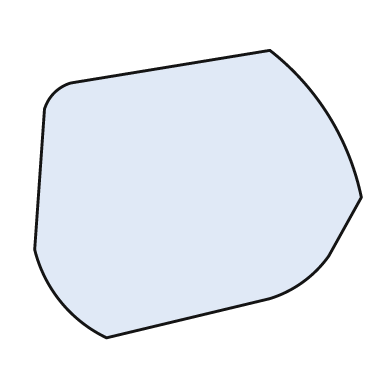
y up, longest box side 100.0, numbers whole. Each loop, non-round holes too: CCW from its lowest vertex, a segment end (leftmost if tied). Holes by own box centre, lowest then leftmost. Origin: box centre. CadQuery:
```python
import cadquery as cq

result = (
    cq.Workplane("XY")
    .moveTo(-28.0, -44.0)
    .lineTo(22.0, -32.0)
    .threePointArc((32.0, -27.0), (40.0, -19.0))
    .lineTo(50.0, -1.0)
    .threePointArc((40.0, 24.0), (22.0, 44.0))
    .lineTo(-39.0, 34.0)
    .threePointArc((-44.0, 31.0), (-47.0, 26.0))
    .lineTo(-50.0, -17.0)
    .threePointArc((-42.0, -33.0), (-28.0, -44.0))
    .close()
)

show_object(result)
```